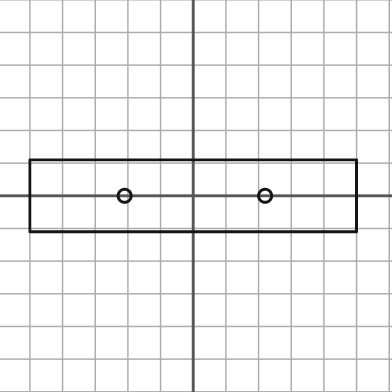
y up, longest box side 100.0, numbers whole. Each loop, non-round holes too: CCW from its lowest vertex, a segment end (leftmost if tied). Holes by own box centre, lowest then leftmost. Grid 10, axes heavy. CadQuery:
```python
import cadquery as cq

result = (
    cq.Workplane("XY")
    .moveTo(-50.0, -11.0)
    .lineTo(50.0, -11.0)
    .lineTo(50.0, 11.0)
    .lineTo(-50.0, 11.0)
    .close()
    .moveTo(-21.0, 0.0)
    .circle(2.0)
    .moveTo(22.0, 0.0)
    .circle(2.0)
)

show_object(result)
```